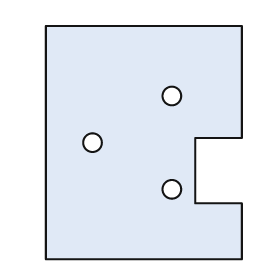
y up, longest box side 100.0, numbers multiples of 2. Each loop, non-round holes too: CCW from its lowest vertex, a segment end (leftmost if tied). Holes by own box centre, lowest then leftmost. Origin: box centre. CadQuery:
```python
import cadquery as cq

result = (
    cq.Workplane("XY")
    .moveTo(-42.0, -50.0)
    .lineTo(42.0, -50.0)
    .lineTo(42.0, -26.0)
    .lineTo(22.0, -26.0)
    .lineTo(22.0, 2.0)
    .lineTo(42.0, 2.0)
    .lineTo(42.0, 50.0)
    .lineTo(-42.0, 50.0)
    .close()
    .moveTo(12.0, -20.0)
    .circle(4.0)
    .moveTo(-22.0, 0.0)
    .circle(4.0)
    .moveTo(12.0, 20.0)
    .circle(4.0)
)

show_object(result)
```